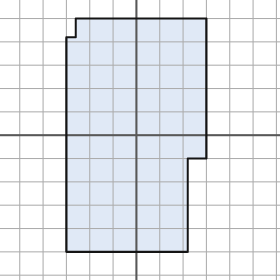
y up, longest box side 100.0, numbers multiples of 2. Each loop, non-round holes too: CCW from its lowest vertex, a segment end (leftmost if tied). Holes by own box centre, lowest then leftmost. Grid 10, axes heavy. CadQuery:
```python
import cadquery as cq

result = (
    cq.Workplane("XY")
    .moveTo(-30.0, -50.0)
    .lineTo(22.0, -50.0)
    .lineTo(22.0, -10.0)
    .lineTo(30.0, -10.0)
    .lineTo(30.0, 50.0)
    .lineTo(-26.0, 50.0)
    .lineTo(-26.0, 42.0)
    .lineTo(-30.0, 42.0)
    .close()
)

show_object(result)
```